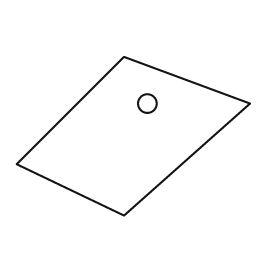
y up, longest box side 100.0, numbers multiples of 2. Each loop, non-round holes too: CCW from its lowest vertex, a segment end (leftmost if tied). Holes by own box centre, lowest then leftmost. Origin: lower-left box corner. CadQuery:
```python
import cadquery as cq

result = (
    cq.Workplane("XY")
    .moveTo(46.0, 0.0)
    .lineTo(100.0, 48.0)
    .lineTo(46.0, 68.0)
    .lineTo(0.0, 22.0)
    .close()
    .moveTo(56.0, 48.0)
    .circle(4.0)
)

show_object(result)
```